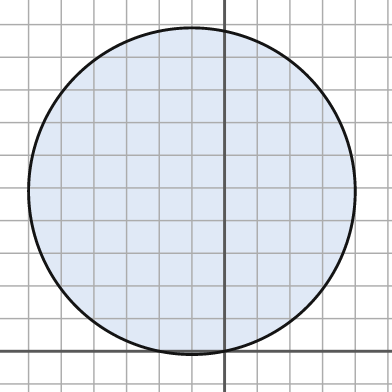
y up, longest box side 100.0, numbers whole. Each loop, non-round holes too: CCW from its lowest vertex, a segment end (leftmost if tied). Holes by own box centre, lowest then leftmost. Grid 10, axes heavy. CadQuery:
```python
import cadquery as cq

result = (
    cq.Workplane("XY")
    .moveTo(-10.0, 49.0)
    .circle(50.0)
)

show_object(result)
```